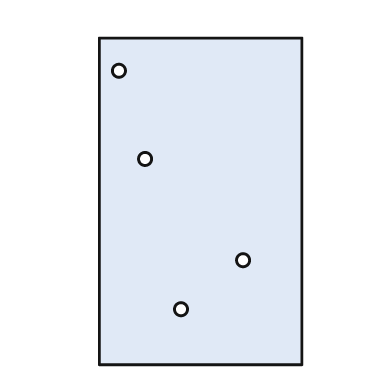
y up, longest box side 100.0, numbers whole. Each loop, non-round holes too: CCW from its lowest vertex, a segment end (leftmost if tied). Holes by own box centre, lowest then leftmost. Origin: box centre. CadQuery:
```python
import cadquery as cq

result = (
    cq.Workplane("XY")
    .moveTo(-31.0, -50.0)
    .lineTo(31.0, -50.0)
    .lineTo(31.0, 50.0)
    .lineTo(-31.0, 50.0)
    .close()
    .moveTo(-6.0, -33.0)
    .circle(2.0)
    .moveTo(13.0, -18.0)
    .circle(2.0)
    .moveTo(-17.0, 13.0)
    .circle(2.0)
    .moveTo(-25.0, 40.0)
    .circle(2.0)
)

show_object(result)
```